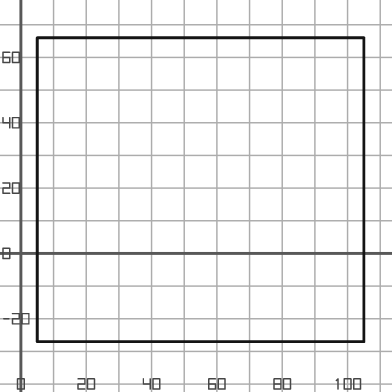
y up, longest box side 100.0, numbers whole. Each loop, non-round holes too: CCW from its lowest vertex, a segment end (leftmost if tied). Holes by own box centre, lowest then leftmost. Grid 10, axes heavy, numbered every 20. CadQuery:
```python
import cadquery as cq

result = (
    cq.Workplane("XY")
    .moveTo(5.0, -27.0)
    .lineTo(105.0, -27.0)
    .lineTo(105.0, 66.0)
    .lineTo(5.0, 66.0)
    .close()
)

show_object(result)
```